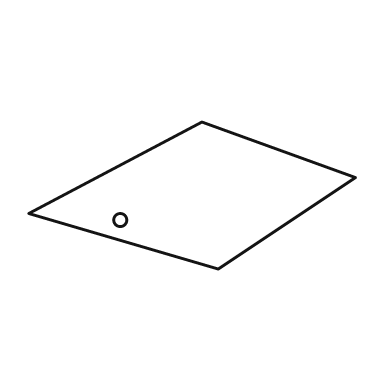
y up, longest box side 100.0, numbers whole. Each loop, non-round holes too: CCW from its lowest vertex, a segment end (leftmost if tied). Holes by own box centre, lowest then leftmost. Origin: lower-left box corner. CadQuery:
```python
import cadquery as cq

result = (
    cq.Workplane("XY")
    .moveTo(58.0, 0.0)
    .lineTo(100.0, 28.0)
    .lineTo(53.0, 45.0)
    .lineTo(0.0, 17.0)
    .close()
    .moveTo(28.0, 15.0)
    .circle(2.0)
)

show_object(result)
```